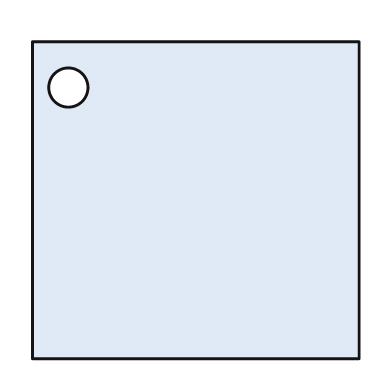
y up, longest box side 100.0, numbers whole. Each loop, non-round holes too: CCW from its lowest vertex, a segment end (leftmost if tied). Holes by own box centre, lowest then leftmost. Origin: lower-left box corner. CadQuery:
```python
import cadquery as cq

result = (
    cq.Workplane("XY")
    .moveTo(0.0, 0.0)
    .lineTo(100.0, 0.0)
    .lineTo(100.0, 97.0)
    .lineTo(0.0, 97.0)
    .close()
    .moveTo(11.0, 83.0)
    .circle(6.0)
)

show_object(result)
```